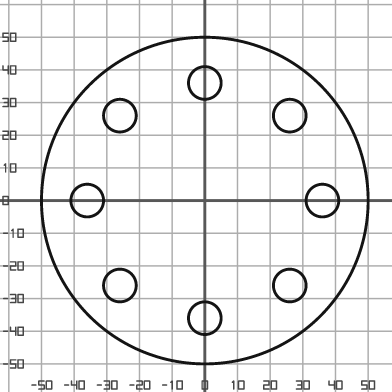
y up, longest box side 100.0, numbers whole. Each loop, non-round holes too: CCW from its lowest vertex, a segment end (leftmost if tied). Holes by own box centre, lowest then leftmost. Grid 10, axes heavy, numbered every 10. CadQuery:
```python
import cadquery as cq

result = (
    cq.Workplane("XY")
    .moveTo(0.0, 0.0)
    .circle(50.0)
    .moveTo(0.0, -36.0)
    .circle(5.0)
    .moveTo(-26.0, -26.0)
    .circle(5.0)
    .moveTo(26.0, -26.0)
    .circle(5.0)
    .moveTo(-36.0, 0.0)
    .circle(5.0)
    .moveTo(36.0, 0.0)
    .circle(5.0)
    .moveTo(-26.0, 26.0)
    .circle(5.0)
    .moveTo(26.0, 26.0)
    .circle(5.0)
    .moveTo(0.0, 36.0)
    .circle(5.0)
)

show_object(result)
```